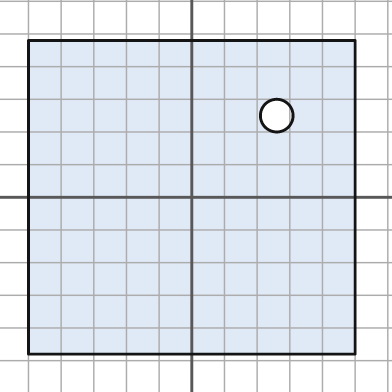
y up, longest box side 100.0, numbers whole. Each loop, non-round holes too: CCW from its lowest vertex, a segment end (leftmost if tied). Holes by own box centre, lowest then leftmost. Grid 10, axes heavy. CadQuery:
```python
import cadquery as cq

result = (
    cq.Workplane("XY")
    .moveTo(-50.0, -48.0)
    .lineTo(50.0, -48.0)
    .lineTo(50.0, 48.0)
    .lineTo(-50.0, 48.0)
    .close()
    .moveTo(26.0, 25.0)
    .circle(5.0)
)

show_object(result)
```